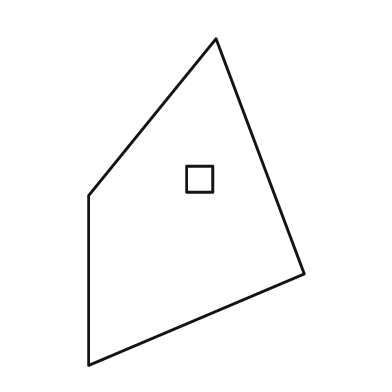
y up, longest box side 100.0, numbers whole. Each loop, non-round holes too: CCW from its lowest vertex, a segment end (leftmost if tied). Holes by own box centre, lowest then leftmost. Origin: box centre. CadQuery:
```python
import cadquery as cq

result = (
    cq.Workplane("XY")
    .moveTo(-33.0, -50.0)
    .lineTo(33.0, -22.0)
    .lineTo(6.0, 50.0)
    .lineTo(-33.0, 2.0)
    .close()
    .moveTo(-3.0, 3.0)
    .lineTo(5.0, 3.0)
    .lineTo(5.0, 11.0)
    .lineTo(-3.0, 11.0)
    .close()
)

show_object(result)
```